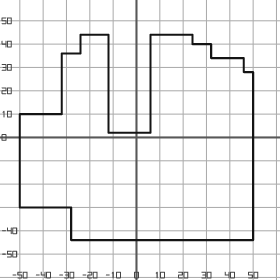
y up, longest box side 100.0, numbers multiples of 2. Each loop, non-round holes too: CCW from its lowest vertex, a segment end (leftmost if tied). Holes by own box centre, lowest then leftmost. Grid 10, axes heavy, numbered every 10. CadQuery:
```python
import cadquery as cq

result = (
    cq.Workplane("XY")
    .moveTo(-28.0, -44.0)
    .lineTo(50.0, -44.0)
    .lineTo(50.0, 28.0)
    .lineTo(46.0, 28.0)
    .lineTo(46.0, 34.0)
    .lineTo(32.0, 34.0)
    .lineTo(32.0, 40.0)
    .lineTo(24.0, 40.0)
    .lineTo(24.0, 44.0)
    .lineTo(6.0, 44.0)
    .lineTo(6.0, 2.0)
    .lineTo(-12.0, 2.0)
    .lineTo(-12.0, 44.0)
    .lineTo(-24.0, 44.0)
    .lineTo(-24.0, 36.0)
    .lineTo(-32.0, 36.0)
    .lineTo(-32.0, 10.0)
    .lineTo(-50.0, 10.0)
    .lineTo(-50.0, -30.0)
    .lineTo(-28.0, -30.0)
    .close()
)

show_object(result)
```